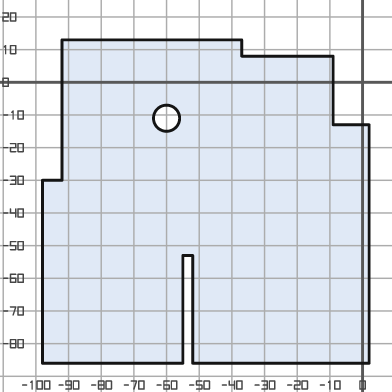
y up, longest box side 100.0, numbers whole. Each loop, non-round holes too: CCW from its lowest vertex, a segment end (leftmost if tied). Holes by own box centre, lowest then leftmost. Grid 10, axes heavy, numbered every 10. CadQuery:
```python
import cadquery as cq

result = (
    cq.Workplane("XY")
    .moveTo(-98.0, -86.0)
    .lineTo(-55.0, -86.0)
    .lineTo(-55.0, -53.0)
    .lineTo(-52.0, -53.0)
    .lineTo(-52.0, -86.0)
    .lineTo(2.0, -86.0)
    .lineTo(2.0, -13.0)
    .lineTo(-9.0, -13.0)
    .lineTo(-9.0, 8.0)
    .lineTo(-37.0, 8.0)
    .lineTo(-37.0, 13.0)
    .lineTo(-92.0, 13.0)
    .lineTo(-92.0, -30.0)
    .lineTo(-98.0, -30.0)
    .close()
    .moveTo(-60.0, -11.0)
    .circle(4.0)
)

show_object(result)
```